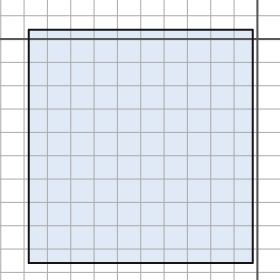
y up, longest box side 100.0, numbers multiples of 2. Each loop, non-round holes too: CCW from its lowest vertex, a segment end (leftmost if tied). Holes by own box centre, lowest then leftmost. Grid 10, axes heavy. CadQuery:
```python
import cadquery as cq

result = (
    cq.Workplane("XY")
    .moveTo(-98.0, -96.0)
    .lineTo(-2.0, -96.0)
    .lineTo(-2.0, 4.0)
    .lineTo(-98.0, 4.0)
    .close()
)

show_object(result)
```